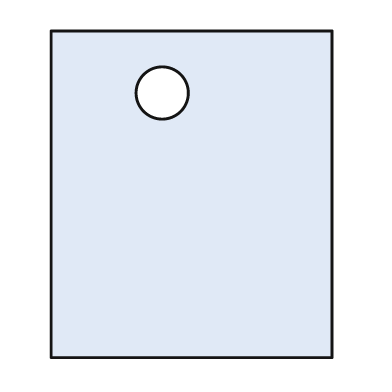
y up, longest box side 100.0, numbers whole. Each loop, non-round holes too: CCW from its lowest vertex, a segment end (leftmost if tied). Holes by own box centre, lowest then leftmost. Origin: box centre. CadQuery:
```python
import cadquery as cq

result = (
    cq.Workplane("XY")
    .moveTo(-43.0, -50.0)
    .lineTo(43.0, -50.0)
    .lineTo(43.0, 50.0)
    .lineTo(-43.0, 50.0)
    .close()
    .moveTo(-9.0, 31.0)
    .circle(8.0)
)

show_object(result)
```